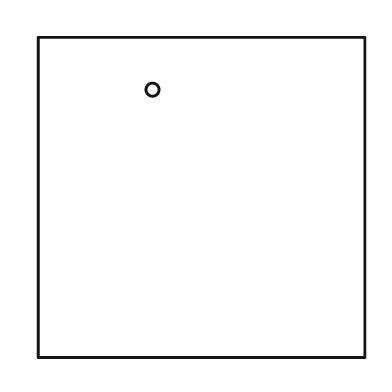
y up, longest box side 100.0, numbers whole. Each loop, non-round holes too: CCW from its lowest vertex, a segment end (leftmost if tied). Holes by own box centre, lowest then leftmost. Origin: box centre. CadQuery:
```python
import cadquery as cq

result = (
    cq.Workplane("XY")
    .moveTo(-50.0, -49.0)
    .lineTo(50.0, -49.0)
    .lineTo(50.0, 49.0)
    .lineTo(-50.0, 49.0)
    .close()
    .moveTo(-15.0, 33.0)
    .circle(2.0)
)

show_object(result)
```